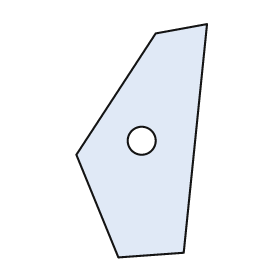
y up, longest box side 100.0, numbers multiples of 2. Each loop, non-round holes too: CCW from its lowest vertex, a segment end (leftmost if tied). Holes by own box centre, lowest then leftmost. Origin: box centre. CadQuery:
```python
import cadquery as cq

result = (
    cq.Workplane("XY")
    .moveTo(-10.0, -50.0)
    .lineTo(18.0, -48.0)
    .lineTo(28.0, 50.0)
    .lineTo(6.0, 46.0)
    .lineTo(-28.0, -6.0)
    .close()
    .moveTo(0.0, 0.0)
    .circle(6.0)
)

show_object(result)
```